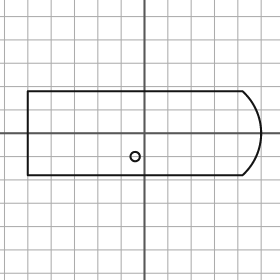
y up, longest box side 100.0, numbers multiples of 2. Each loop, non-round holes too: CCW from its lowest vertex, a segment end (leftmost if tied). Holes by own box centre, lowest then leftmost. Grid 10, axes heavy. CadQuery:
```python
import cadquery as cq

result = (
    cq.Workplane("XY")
    .moveTo(-50.0, -18.0)
    .lineTo(42.0, -18.0)
    .threePointArc((50.0, 0.0), (42.0, 18.0))
    .lineTo(-50.0, 18.0)
    .close()
    .moveTo(-4.0, -10.0)
    .circle(2.0)
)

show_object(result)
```